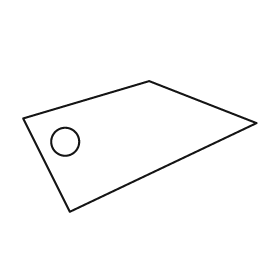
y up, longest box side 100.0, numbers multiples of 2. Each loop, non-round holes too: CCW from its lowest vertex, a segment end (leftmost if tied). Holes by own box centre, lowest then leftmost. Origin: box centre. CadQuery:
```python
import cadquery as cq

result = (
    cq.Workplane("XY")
    .moveTo(-30.0, -28.0)
    .lineTo(50.0, 10.0)
    .lineTo(4.0, 28.0)
    .lineTo(-50.0, 12.0)
    .close()
    .moveTo(-32.0, 2.0)
    .circle(6.0)
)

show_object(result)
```